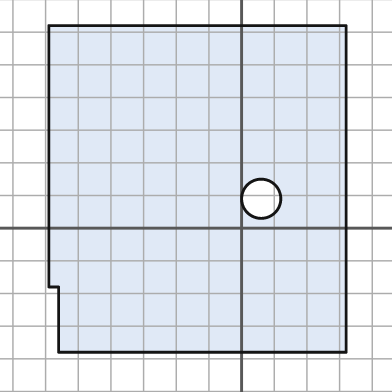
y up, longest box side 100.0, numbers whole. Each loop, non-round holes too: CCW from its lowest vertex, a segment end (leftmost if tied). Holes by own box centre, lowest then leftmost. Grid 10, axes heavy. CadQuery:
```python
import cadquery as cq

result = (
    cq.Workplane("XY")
    .moveTo(-56.0, -38.0)
    .lineTo(32.0, -38.0)
    .lineTo(32.0, 62.0)
    .lineTo(-59.0, 62.0)
    .lineTo(-59.0, -18.0)
    .lineTo(-56.0, -18.0)
    .close()
    .moveTo(6.0, 9.0)
    .circle(6.0)
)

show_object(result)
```